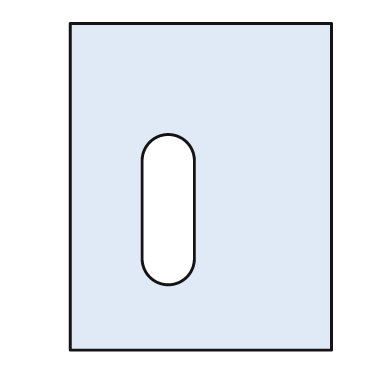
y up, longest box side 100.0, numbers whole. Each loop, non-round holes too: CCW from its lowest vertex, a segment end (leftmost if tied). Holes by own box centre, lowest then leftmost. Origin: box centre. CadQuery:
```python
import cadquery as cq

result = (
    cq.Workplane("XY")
    .moveTo(-40.0, -50.0)
    .lineTo(40.0, -50.0)
    .lineTo(40.0, 50.0)
    .lineTo(-40.0, 50.0)
    .close()
    .moveTo(-18.0, -22.0)
    .threePointArc((-10.0, -30.0), (-2.0, -22.0))
    .lineTo(-2.0, 8.0)
    .threePointArc((-10.0, 16.0), (-18.0, 8.0))
    .close()
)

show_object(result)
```